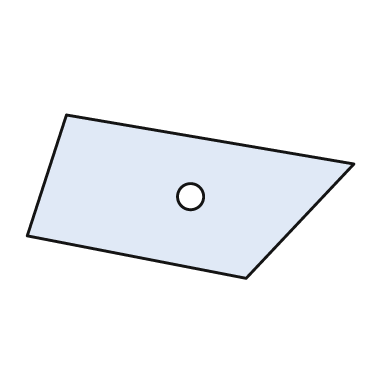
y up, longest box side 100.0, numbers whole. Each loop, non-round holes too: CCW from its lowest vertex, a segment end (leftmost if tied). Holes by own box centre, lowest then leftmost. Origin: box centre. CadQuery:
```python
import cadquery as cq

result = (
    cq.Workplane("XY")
    .moveTo(17.0, -25.0)
    .lineTo(50.0, 10.0)
    .lineTo(-38.0, 25.0)
    .lineTo(-50.0, -12.0)
    .close()
    .moveTo(0.0, 0.0)
    .circle(4.0)
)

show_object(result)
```